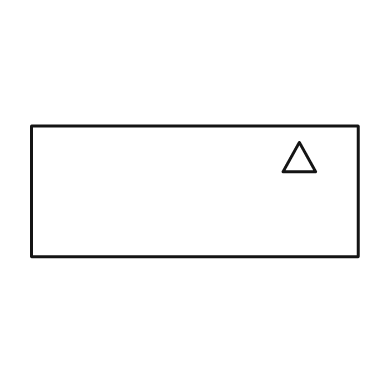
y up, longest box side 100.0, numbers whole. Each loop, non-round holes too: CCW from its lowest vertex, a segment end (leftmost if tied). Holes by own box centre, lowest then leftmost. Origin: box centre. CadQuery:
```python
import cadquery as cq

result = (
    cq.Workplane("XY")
    .moveTo(-50.0, -20.0)
    .lineTo(50.0, -20.0)
    .lineTo(50.0, 20.0)
    .lineTo(-50.0, 20.0)
    .close()
    .moveTo(27.0, 6.0)
    .lineTo(37.0, 6.0)
    .lineTo(32.0, 15.0)
    .close()
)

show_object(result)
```